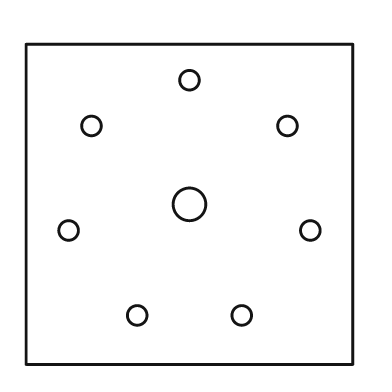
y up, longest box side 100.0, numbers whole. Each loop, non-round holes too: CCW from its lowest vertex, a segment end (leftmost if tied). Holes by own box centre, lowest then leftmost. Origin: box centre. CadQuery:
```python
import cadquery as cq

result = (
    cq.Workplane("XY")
    .moveTo(-50.0, -49.0)
    .lineTo(50.0, -49.0)
    .lineTo(50.0, 49.0)
    .lineTo(-50.0, 49.0)
    .close()
    .moveTo(-16.0, -34.0)
    .circle(3.0)
    .moveTo(16.0, -34.0)
    .circle(3.0)
    .moveTo(-37.0, -8.0)
    .circle(3.0)
    .moveTo(37.0, -8.0)
    .circle(3.0)
    .moveTo(0.0, 0.0)
    .circle(5.0)
    .moveTo(-30.0, 24.0)
    .circle(3.0)
    .moveTo(30.0, 24.0)
    .circle(3.0)
    .moveTo(0.0, 38.0)
    .circle(3.0)
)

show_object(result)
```